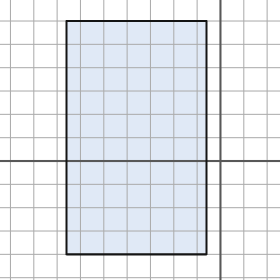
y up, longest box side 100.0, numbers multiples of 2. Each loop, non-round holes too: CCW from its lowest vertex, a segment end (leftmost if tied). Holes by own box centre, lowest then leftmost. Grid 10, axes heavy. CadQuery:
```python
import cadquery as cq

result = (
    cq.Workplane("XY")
    .moveTo(-66.0, -40.0)
    .lineTo(-6.0, -40.0)
    .lineTo(-6.0, 60.0)
    .lineTo(-66.0, 60.0)
    .close()
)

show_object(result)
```